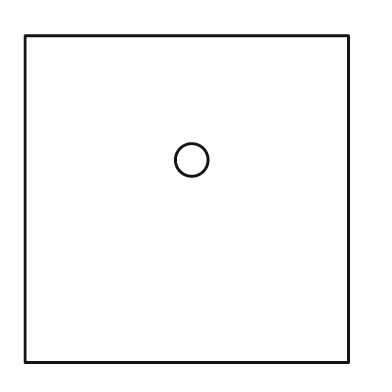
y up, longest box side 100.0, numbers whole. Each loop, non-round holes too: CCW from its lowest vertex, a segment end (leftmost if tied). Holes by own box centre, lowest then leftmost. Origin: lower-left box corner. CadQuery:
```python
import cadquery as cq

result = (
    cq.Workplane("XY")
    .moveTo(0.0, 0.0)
    .lineTo(99.0, 0.0)
    .lineTo(99.0, 100.0)
    .lineTo(0.0, 100.0)
    .close()
    .moveTo(51.0, 62.0)
    .circle(5.0)
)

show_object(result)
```